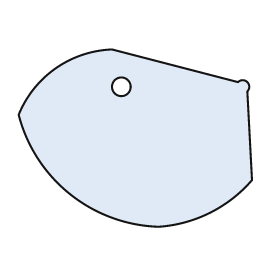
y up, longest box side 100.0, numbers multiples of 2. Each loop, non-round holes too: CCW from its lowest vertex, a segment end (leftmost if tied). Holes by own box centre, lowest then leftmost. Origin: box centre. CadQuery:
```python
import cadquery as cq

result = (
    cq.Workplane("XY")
    .moveTo(10.0, -38.0)
    .threePointArc((32.0, -32.0), (50.0, -18.0))
    .lineTo(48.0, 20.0)
    .threePointArc((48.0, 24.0), (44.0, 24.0))
    .lineTo(-10.0, 38.0)
    .threePointArc((-34.0, 30.0), (-50.0, 10.0))
    .threePointArc((-28.0, -24.0), (10.0, -38.0))
    .close()
    .moveTo(-6.0, 22.0)
    .circle(4.0)
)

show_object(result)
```